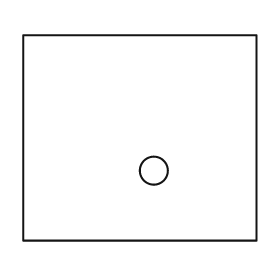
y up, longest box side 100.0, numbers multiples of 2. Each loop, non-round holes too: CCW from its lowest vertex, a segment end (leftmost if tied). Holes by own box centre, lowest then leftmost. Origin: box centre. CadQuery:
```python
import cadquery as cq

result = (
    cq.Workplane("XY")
    .moveTo(-50.0, -44.0)
    .lineTo(50.0, -44.0)
    .lineTo(50.0, 44.0)
    .lineTo(-50.0, 44.0)
    .close()
    .moveTo(6.0, -14.0)
    .circle(6.0)
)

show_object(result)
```